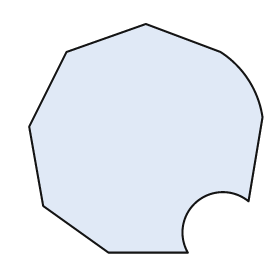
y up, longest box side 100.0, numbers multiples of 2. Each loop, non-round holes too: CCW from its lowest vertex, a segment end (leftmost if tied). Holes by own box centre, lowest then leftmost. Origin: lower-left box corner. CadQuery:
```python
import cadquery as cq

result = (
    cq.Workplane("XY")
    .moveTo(34.0, 0.0)
    .lineTo(68.0, 0.0)
    .threePointArc((72.0, 22.0), (94.0, 22.0))
    .lineTo(100.0, 58.0)
    .threePointArc((94.0, 74.0), (82.0, 86.0))
    .lineTo(50.0, 98.0)
    .lineTo(16.0, 86.0)
    .lineTo(0.0, 54.0)
    .lineTo(6.0, 20.0)
    .close()
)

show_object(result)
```